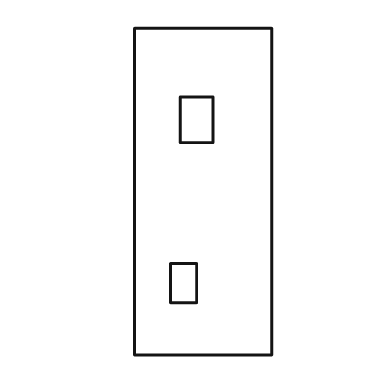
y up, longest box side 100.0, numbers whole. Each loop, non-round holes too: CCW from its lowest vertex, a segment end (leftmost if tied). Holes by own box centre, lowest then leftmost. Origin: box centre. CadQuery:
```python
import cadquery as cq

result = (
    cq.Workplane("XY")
    .moveTo(-21.0, -50.0)
    .lineTo(21.0, -50.0)
    .lineTo(21.0, 50.0)
    .lineTo(-21.0, 50.0)
    .close()
    .moveTo(-10.0, -34.0)
    .lineTo(-2.0, -34.0)
    .lineTo(-2.0, -22.0)
    .lineTo(-10.0, -22.0)
    .close()
    .moveTo(-7.0, 15.0)
    .lineTo(3.0, 15.0)
    .lineTo(3.0, 29.0)
    .lineTo(-7.0, 29.0)
    .close()
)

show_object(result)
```